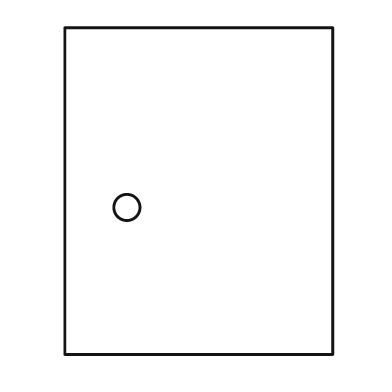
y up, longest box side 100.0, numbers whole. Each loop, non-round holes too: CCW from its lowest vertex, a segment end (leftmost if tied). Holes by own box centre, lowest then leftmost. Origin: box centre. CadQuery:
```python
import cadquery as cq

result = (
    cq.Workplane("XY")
    .moveTo(-41.0, -50.0)
    .lineTo(41.0, -50.0)
    .lineTo(41.0, 50.0)
    .lineTo(-41.0, 50.0)
    .close()
    .moveTo(-22.0, -5.0)
    .circle(4.0)
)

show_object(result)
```